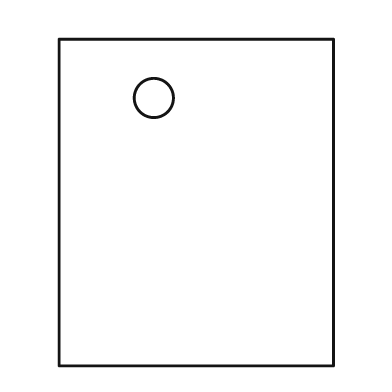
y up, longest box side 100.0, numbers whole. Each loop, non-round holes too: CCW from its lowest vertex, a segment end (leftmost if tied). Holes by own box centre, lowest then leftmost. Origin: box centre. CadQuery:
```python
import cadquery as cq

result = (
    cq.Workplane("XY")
    .moveTo(-42.0, -50.0)
    .lineTo(42.0, -50.0)
    .lineTo(42.0, 50.0)
    .lineTo(-42.0, 50.0)
    .close()
    .moveTo(-13.0, 32.0)
    .circle(6.0)
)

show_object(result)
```